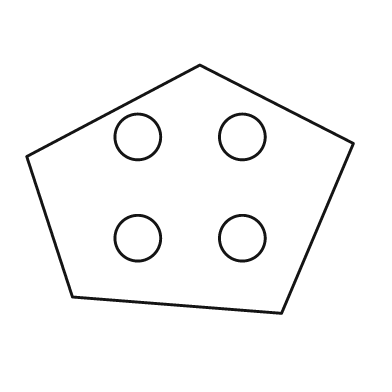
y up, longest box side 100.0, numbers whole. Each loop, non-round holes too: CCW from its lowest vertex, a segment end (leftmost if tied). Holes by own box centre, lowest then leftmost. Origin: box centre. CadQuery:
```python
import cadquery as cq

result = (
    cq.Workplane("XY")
    .moveTo(28.0, -38.0)
    .lineTo(50.0, 14.0)
    .lineTo(3.0, 38.0)
    .lineTo(-50.0, 10.0)
    .lineTo(-36.0, -33.0)
    .close()
    .moveTo(-16.0, -15.0)
    .circle(7.0)
    .moveTo(16.0, -15.0)
    .circle(7.0)
    .moveTo(-16.0, 16.0)
    .circle(7.0)
    .moveTo(16.0, 16.0)
    .circle(7.0)
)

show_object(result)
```